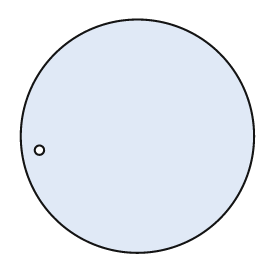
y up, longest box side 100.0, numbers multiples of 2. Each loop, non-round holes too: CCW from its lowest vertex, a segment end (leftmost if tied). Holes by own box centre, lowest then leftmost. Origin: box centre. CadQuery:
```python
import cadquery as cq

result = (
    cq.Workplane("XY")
    .moveTo(0.0, 0.0)
    .circle(50.0)
    .moveTo(-42.0, -6.0)
    .circle(2.0)
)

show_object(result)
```